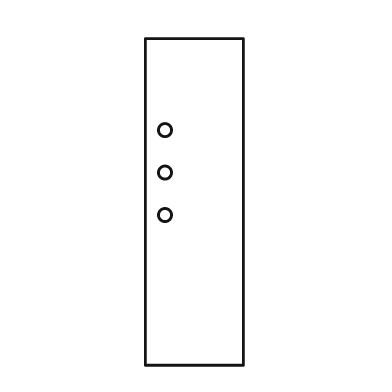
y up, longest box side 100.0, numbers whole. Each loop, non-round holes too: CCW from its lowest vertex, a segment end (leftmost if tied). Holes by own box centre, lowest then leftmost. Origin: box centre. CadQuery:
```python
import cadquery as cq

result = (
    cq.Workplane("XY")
    .moveTo(-15.0, -50.0)
    .lineTo(15.0, -50.0)
    .lineTo(15.0, 50.0)
    .lineTo(-15.0, 50.0)
    .close()
    .moveTo(-9.0, -4.0)
    .circle(2.0)
    .moveTo(-9.0, 9.0)
    .circle(2.0)
    .moveTo(-9.0, 22.0)
    .circle(2.0)
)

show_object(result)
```